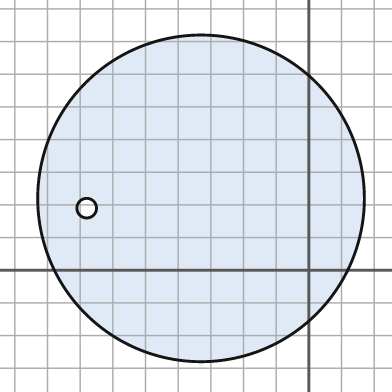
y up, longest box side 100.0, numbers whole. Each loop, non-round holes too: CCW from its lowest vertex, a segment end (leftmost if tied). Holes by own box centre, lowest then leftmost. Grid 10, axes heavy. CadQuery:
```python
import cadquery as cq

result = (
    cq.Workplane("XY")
    .moveTo(-33.0, 22.0)
    .circle(50.0)
    .moveTo(-68.0, 19.0)
    .circle(3.0)
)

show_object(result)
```